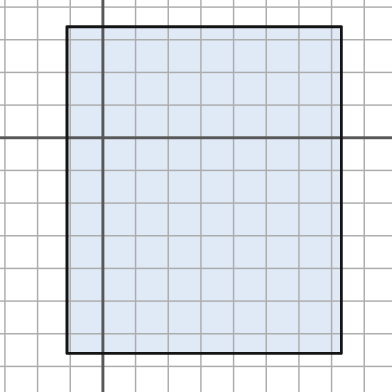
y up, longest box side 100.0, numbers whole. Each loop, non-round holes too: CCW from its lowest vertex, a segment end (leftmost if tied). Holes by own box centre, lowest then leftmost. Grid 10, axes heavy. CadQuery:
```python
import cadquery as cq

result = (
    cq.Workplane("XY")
    .moveTo(-11.0, -66.0)
    .lineTo(73.0, -66.0)
    .lineTo(73.0, 34.0)
    .lineTo(-11.0, 34.0)
    .close()
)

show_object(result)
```